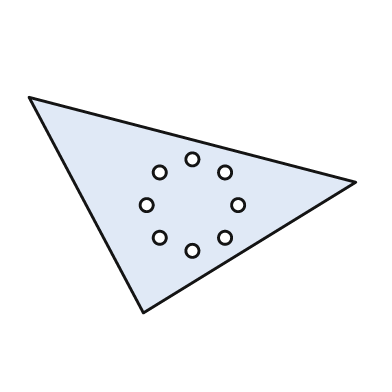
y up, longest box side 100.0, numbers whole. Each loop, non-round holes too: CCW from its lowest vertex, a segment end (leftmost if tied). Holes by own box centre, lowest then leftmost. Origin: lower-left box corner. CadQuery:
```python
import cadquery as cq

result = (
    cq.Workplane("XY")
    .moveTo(35.0, 0.0)
    .lineTo(100.0, 40.0)
    .lineTo(0.0, 66.0)
    .close()
    .moveTo(50.0, 19.0)
    .circle(2.0)
    .moveTo(40.0, 23.0)
    .circle(2.0)
    .moveTo(60.0, 23.0)
    .circle(2.0)
    .moveTo(36.0, 33.0)
    .circle(2.0)
    .moveTo(64.0, 33.0)
    .circle(2.0)
    .moveTo(40.0, 43.0)
    .circle(2.0)
    .moveTo(60.0, 43.0)
    .circle(2.0)
    .moveTo(50.0, 47.0)
    .circle(2.0)
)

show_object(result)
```